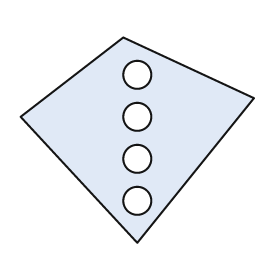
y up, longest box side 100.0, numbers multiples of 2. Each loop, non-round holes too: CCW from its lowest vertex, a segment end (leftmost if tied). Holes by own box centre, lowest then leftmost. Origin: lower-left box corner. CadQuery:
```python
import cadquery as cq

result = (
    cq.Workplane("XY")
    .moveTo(50.0, 0.0)
    .lineTo(100.0, 62.0)
    .lineTo(44.0, 88.0)
    .lineTo(0.0, 54.0)
    .close()
    .moveTo(50.0, 18.0)
    .circle(6.0)
    .moveTo(50.0, 36.0)
    .circle(6.0)
    .moveTo(50.0, 54.0)
    .circle(6.0)
    .moveTo(50.0, 72.0)
    .circle(6.0)
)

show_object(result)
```